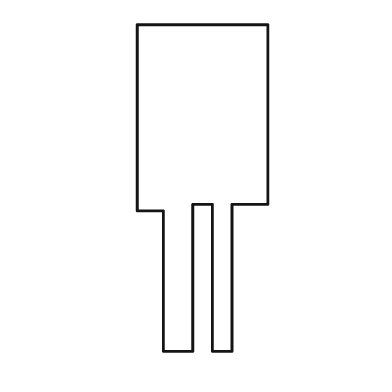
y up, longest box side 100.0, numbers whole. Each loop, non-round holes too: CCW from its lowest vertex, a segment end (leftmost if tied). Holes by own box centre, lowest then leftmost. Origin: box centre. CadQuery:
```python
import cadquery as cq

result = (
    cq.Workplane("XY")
    .moveTo(-12.0, -50.0)
    .lineTo(-3.0, -50.0)
    .lineTo(-3.0, -5.0)
    .lineTo(3.0, -5.0)
    .lineTo(3.0, -50.0)
    .lineTo(9.0, -50.0)
    .lineTo(9.0, -5.0)
    .lineTo(20.0, -5.0)
    .lineTo(20.0, 50.0)
    .lineTo(-20.0, 50.0)
    .lineTo(-20.0, -7.0)
    .lineTo(-12.0, -7.0)
    .close()
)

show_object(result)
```